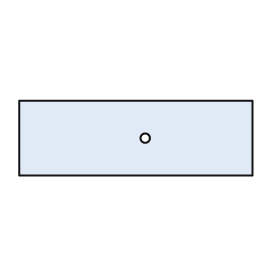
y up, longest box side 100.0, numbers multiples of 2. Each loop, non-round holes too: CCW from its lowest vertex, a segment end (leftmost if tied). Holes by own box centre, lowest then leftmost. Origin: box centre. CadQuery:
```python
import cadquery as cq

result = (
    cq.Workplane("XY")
    .moveTo(-50.0, -16.0)
    .lineTo(50.0, -16.0)
    .lineTo(50.0, 16.0)
    .lineTo(-50.0, 16.0)
    .close()
    .moveTo(4.0, 0.0)
    .circle(2.0)
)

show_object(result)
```